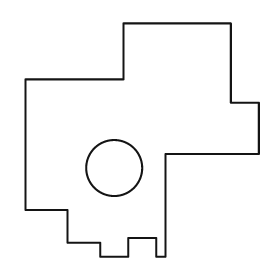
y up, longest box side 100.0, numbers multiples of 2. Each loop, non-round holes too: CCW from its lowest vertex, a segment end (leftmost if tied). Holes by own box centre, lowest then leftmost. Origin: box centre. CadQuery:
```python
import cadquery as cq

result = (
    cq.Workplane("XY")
    .moveTo(-18.0, -50.0)
    .lineTo(-6.0, -50.0)
    .lineTo(-6.0, -42.0)
    .lineTo(6.0, -42.0)
    .lineTo(6.0, -50.0)
    .lineTo(10.0, -50.0)
    .lineTo(10.0, -6.0)
    .lineTo(50.0, -6.0)
    .lineTo(50.0, 16.0)
    .lineTo(38.0, 16.0)
    .lineTo(38.0, 50.0)
    .lineTo(-8.0, 50.0)
    .lineTo(-8.0, 26.0)
    .lineTo(-50.0, 26.0)
    .lineTo(-50.0, -30.0)
    .lineTo(-32.0, -30.0)
    .lineTo(-32.0, -44.0)
    .lineTo(-18.0, -44.0)
    .close()
    .moveTo(-12.0, -12.0)
    .circle(12.0)
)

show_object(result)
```